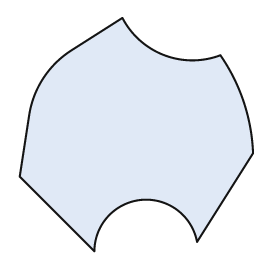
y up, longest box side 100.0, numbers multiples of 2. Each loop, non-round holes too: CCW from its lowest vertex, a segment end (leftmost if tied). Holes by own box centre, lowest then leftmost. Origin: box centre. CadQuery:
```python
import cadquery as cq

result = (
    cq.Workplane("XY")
    .moveTo(-18.0, -50.0)
    .threePointArc((2.0, -28.0), (26.0, -46.0))
    .lineTo(50.0, -8.0)
    .threePointArc((46.0, 14.0), (36.0, 34.0))
    .threePointArc((12.0, 34.0), (-6.0, 50.0))
    .lineTo(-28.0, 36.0)
    .threePointArc((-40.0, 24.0), (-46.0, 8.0))
    .lineTo(-50.0, -18.0)
    .close()
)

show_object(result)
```